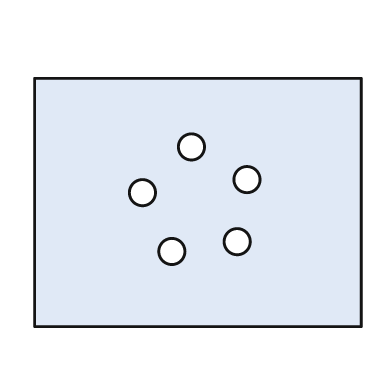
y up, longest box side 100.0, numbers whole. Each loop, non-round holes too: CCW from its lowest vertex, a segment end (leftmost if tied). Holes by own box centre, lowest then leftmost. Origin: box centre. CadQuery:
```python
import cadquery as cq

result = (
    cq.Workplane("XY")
    .moveTo(-50.0, -38.0)
    .lineTo(50.0, -38.0)
    .lineTo(50.0, 38.0)
    .lineTo(-50.0, 38.0)
    .close()
    .moveTo(-8.0, -15.0)
    .circle(4.0)
    .moveTo(12.0, -12.0)
    .circle(4.0)
    .moveTo(-17.0, 3.0)
    .circle(4.0)
    .moveTo(15.0, 7.0)
    .circle(4.0)
    .moveTo(-2.0, 17.0)
    .circle(4.0)
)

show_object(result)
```